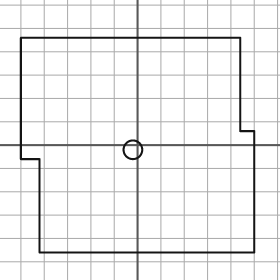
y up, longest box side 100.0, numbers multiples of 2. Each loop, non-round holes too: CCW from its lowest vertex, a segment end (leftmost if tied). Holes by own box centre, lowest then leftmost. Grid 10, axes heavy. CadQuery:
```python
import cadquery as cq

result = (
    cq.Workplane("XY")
    .moveTo(-42.0, -46.0)
    .lineTo(50.0, -46.0)
    .lineTo(50.0, 6.0)
    .lineTo(44.0, 6.0)
    .lineTo(44.0, 46.0)
    .lineTo(-50.0, 46.0)
    .lineTo(-50.0, -6.0)
    .lineTo(-42.0, -6.0)
    .close()
    .moveTo(-2.0, -2.0)
    .circle(4.0)
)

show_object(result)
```